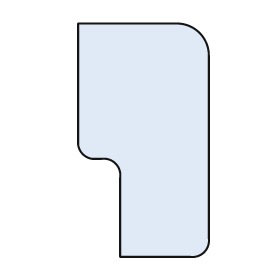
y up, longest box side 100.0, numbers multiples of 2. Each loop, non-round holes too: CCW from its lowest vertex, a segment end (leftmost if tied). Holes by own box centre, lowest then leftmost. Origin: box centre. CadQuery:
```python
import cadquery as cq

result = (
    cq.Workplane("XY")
    .moveTo(-10.0, -50.0)
    .lineTo(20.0, -50.0)
    .threePointArc((26.0, -48.0), (28.0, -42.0))
    .lineTo(28.0, 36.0)
    .threePointArc((24.0, 46.0), (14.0, 50.0))
    .lineTo(-28.0, 50.0)
    .lineTo(-28.0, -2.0)
    .threePointArc((-26.0, -6.0), (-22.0, -8.0))
    .lineTo(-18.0, -8.0)
    .threePointArc((-12.0, -10.0), (-10.0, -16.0))
    .close()
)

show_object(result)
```